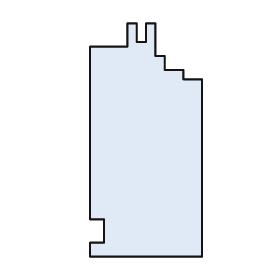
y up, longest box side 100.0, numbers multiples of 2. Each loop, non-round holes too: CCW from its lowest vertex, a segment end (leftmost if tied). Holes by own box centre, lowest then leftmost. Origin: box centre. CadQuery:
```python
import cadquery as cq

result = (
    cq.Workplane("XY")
    .moveTo(-24.0, -50.0)
    .lineTo(24.0, -50.0)
    .lineTo(24.0, 26.0)
    .lineTo(16.0, 26.0)
    .lineTo(16.0, 30.0)
    .lineTo(8.0, 30.0)
    .lineTo(8.0, 36.0)
    .lineTo(4.0, 36.0)
    .lineTo(4.0, 50.0)
    .lineTo(0.0, 50.0)
    .lineTo(0.0, 42.0)
    .lineTo(-4.0, 42.0)
    .lineTo(-4.0, 50.0)
    .lineTo(-8.0, 50.0)
    .lineTo(-8.0, 40.0)
    .lineTo(-24.0, 40.0)
    .lineTo(-24.0, -34.0)
    .lineTo(-18.0, -34.0)
    .lineTo(-18.0, -44.0)
    .lineTo(-24.0, -44.0)
    .close()
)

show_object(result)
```